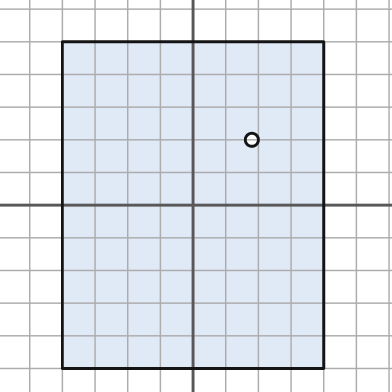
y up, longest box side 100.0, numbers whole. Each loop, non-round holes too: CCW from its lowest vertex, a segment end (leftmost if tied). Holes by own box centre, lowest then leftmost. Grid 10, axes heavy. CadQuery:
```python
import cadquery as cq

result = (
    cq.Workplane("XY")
    .moveTo(-40.0, -50.0)
    .lineTo(40.0, -50.0)
    .lineTo(40.0, 50.0)
    .lineTo(-40.0, 50.0)
    .close()
    .moveTo(18.0, 20.0)
    .circle(2.0)
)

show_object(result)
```